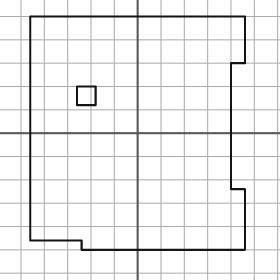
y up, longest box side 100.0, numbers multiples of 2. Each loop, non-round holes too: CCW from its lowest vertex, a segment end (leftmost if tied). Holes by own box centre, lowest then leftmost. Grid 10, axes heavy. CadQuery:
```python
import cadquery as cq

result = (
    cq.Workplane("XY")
    .moveTo(-24.0, -50.0)
    .lineTo(46.0, -50.0)
    .lineTo(46.0, -24.0)
    .lineTo(40.0, -24.0)
    .lineTo(40.0, 30.0)
    .lineTo(46.0, 30.0)
    .lineTo(46.0, 50.0)
    .lineTo(-46.0, 50.0)
    .lineTo(-46.0, -46.0)
    .lineTo(-24.0, -46.0)
    .close()
    .moveTo(-26.0, 12.0)
    .lineTo(-18.0, 12.0)
    .lineTo(-18.0, 20.0)
    .lineTo(-26.0, 20.0)
    .close()
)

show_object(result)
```